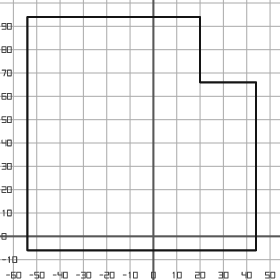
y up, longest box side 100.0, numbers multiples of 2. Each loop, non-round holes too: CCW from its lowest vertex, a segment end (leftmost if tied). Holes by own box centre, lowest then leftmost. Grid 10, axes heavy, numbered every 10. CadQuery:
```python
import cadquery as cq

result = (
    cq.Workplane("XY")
    .moveTo(-54.0, -6.0)
    .lineTo(44.0, -6.0)
    .lineTo(44.0, 66.0)
    .lineTo(20.0, 66.0)
    .lineTo(20.0, 94.0)
    .lineTo(-54.0, 94.0)
    .close()
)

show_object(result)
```